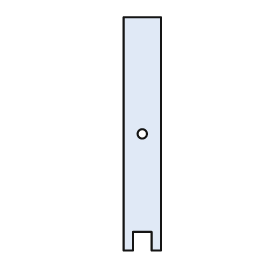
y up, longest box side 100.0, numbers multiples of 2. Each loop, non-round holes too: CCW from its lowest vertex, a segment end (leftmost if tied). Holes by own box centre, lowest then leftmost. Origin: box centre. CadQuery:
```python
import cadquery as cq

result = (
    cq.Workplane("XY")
    .moveTo(-8.0, -50.0)
    .lineTo(-4.0, -50.0)
    .lineTo(-4.0, -42.0)
    .lineTo(4.0, -42.0)
    .lineTo(4.0, -50.0)
    .lineTo(8.0, -50.0)
    .lineTo(8.0, 50.0)
    .lineTo(-8.0, 50.0)
    .close()
    .moveTo(0.0, 0.0)
    .circle(2.0)
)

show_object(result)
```